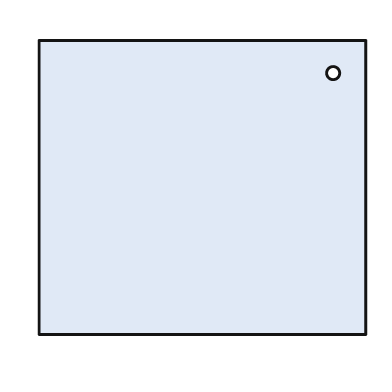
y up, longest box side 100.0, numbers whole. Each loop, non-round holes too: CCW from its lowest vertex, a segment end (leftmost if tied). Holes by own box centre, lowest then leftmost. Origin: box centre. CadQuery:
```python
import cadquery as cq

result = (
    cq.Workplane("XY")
    .moveTo(-50.0, -45.0)
    .lineTo(50.0, -45.0)
    .lineTo(50.0, 45.0)
    .lineTo(-50.0, 45.0)
    .close()
    .moveTo(40.0, 35.0)
    .circle(2.0)
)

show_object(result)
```